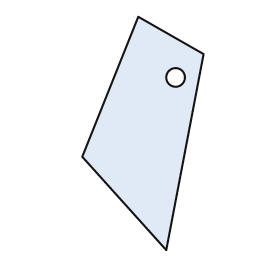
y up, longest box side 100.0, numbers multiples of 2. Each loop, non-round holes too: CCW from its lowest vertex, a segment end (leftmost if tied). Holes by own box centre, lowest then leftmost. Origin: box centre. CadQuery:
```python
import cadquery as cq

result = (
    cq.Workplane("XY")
    .moveTo(10.0, -50.0)
    .lineTo(26.0, 34.0)
    .lineTo(-2.0, 50.0)
    .lineTo(-26.0, -10.0)
    .close()
    .moveTo(14.0, 24.0)
    .circle(4.0)
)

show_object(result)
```